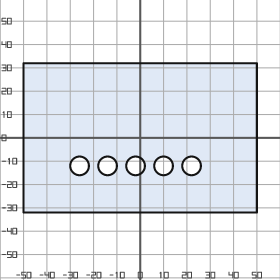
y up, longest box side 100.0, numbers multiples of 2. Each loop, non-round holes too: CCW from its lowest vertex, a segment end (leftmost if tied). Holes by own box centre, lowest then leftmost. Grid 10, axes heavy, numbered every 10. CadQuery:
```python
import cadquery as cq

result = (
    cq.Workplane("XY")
    .moveTo(-50.0, -32.0)
    .lineTo(50.0, -32.0)
    .lineTo(50.0, 32.0)
    .lineTo(-50.0, 32.0)
    .close()
    .moveTo(-26.0, -12.0)
    .circle(4.0)
    .moveTo(-14.0, -12.0)
    .circle(4.0)
    .moveTo(-2.0, -12.0)
    .circle(4.0)
    .moveTo(10.0, -12.0)
    .circle(4.0)
    .moveTo(22.0, -12.0)
    .circle(4.0)
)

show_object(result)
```